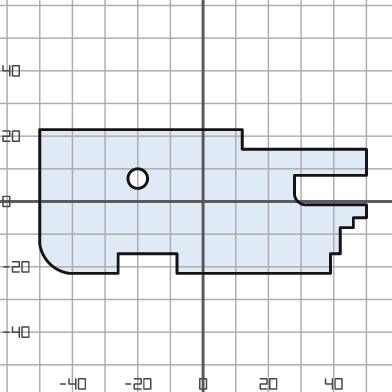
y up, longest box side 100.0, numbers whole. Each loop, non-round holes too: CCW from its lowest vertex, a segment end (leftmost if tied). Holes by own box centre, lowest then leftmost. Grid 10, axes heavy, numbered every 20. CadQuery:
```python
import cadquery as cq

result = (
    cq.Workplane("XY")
    .moveTo(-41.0, -22.0)
    .lineTo(-26.0, -22.0)
    .lineTo(-26.0, -16.0)
    .lineTo(-8.0, -16.0)
    .lineTo(-8.0, -22.0)
    .lineTo(39.0, -22.0)
    .lineTo(39.0, -16.0)
    .lineTo(42.0, -16.0)
    .lineTo(42.0, -8.0)
    .lineTo(46.0, -8.0)
    .lineTo(46.0, -5.0)
    .lineTo(50.0, -5.0)
    .lineTo(50.0, -1.0)
    .lineTo(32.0, -1.0)
    .threePointArc((29.0, 0.0), (28.0, 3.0))
    .lineTo(28.0, 8.0)
    .lineTo(50.0, 8.0)
    .lineTo(50.0, 16.0)
    .lineTo(12.0, 16.0)
    .lineTo(12.0, 22.0)
    .lineTo(-50.0, 22.0)
    .lineTo(-50.0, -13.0)
    .threePointArc((-47.0, -19.0), (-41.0, -22.0))
    .close()
    .moveTo(-20.0, 7.0)
    .circle(3.0)
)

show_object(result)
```